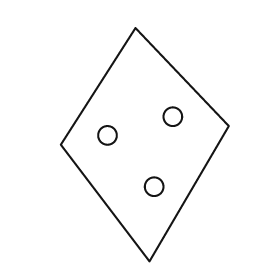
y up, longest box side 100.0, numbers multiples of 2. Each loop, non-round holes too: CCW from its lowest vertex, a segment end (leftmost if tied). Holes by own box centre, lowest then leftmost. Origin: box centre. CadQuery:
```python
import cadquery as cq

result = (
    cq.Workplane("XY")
    .moveTo(2.0, -50.0)
    .lineTo(36.0, 8.0)
    .lineTo(-4.0, 50.0)
    .lineTo(-36.0, 0.0)
    .close()
    .moveTo(4.0, -18.0)
    .circle(4.0)
    .moveTo(-16.0, 4.0)
    .circle(4.0)
    .moveTo(12.0, 12.0)
    .circle(4.0)
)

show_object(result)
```